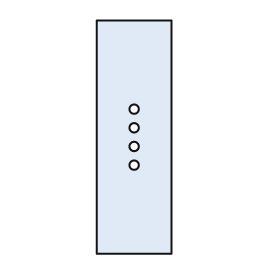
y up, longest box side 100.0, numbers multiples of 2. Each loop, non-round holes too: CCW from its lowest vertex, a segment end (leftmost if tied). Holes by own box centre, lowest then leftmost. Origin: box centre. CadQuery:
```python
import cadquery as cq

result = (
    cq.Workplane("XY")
    .moveTo(-16.0, -50.0)
    .lineTo(16.0, -50.0)
    .lineTo(16.0, 50.0)
    .lineTo(-16.0, 50.0)
    .close()
    .moveTo(0.0, -12.0)
    .circle(2.0)
    .moveTo(0.0, -4.0)
    .circle(2.0)
    .moveTo(0.0, 4.0)
    .circle(2.0)
    .moveTo(0.0, 12.0)
    .circle(2.0)
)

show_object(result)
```